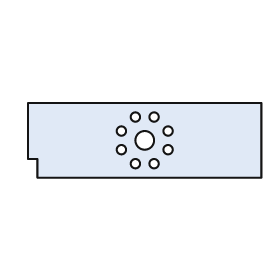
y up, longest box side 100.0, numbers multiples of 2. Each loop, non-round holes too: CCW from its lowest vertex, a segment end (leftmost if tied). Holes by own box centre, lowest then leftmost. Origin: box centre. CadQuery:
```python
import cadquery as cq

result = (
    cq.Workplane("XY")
    .moveTo(-46.0, -16.0)
    .lineTo(50.0, -16.0)
    .lineTo(50.0, 16.0)
    .lineTo(-50.0, 16.0)
    .lineTo(-50.0, -8.0)
    .lineTo(-46.0, -8.0)
    .close()
    .moveTo(-4.0, -10.0)
    .circle(2.0)
    .moveTo(4.0, -10.0)
    .circle(2.0)
    .moveTo(-10.0, -4.0)
    .circle(2.0)
    .moveTo(10.0, -4.0)
    .circle(2.0)
    .moveTo(0.0, 0.0)
    .circle(4.0)
    .moveTo(-10.0, 4.0)
    .circle(2.0)
    .moveTo(10.0, 4.0)
    .circle(2.0)
    .moveTo(-4.0, 10.0)
    .circle(2.0)
    .moveTo(4.0, 10.0)
    .circle(2.0)
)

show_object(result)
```